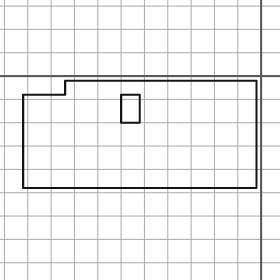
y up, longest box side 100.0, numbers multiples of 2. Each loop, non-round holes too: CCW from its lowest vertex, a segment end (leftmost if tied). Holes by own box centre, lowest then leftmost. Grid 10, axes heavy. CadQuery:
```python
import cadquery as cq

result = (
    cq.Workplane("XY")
    .moveTo(-102.0, -48.0)
    .lineTo(-2.0, -48.0)
    .lineTo(-2.0, -2.0)
    .lineTo(-84.0, -2.0)
    .lineTo(-84.0, -8.0)
    .lineTo(-102.0, -8.0)
    .close()
    .moveTo(-60.0, -20.0)
    .lineTo(-52.0, -20.0)
    .lineTo(-52.0, -8.0)
    .lineTo(-60.0, -8.0)
    .close()
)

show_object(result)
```